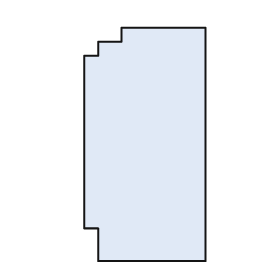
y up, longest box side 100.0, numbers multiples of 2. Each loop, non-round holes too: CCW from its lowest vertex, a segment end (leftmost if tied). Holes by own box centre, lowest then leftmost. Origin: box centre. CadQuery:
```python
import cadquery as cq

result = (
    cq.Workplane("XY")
    .moveTo(-20.0, -50.0)
    .lineTo(26.0, -50.0)
    .lineTo(26.0, 50.0)
    .lineTo(-10.0, 50.0)
    .lineTo(-10.0, 44.0)
    .lineTo(-20.0, 44.0)
    .lineTo(-20.0, 38.0)
    .lineTo(-26.0, 38.0)
    .lineTo(-26.0, -36.0)
    .lineTo(-20.0, -36.0)
    .close()
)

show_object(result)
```